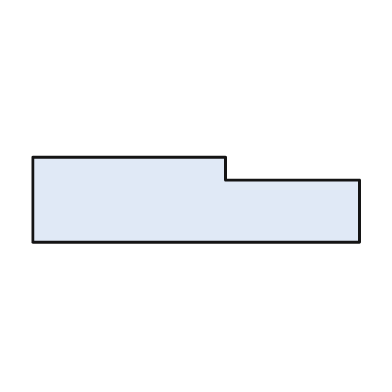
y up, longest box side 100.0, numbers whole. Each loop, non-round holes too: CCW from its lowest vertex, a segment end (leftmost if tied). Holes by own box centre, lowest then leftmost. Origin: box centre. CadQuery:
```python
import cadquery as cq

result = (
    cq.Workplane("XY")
    .moveTo(-50.0, -13.0)
    .lineTo(50.0, -13.0)
    .lineTo(50.0, 6.0)
    .lineTo(9.0, 6.0)
    .lineTo(9.0, 13.0)
    .lineTo(-50.0, 13.0)
    .close()
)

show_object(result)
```